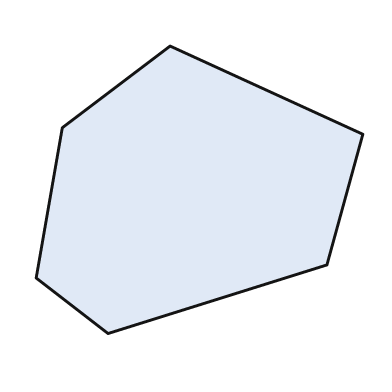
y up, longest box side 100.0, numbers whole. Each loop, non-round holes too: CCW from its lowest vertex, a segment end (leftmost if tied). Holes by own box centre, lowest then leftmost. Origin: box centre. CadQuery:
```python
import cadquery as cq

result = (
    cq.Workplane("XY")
    .moveTo(-28.0, -44.0)
    .lineTo(39.0, -23.0)
    .lineTo(50.0, 17.0)
    .lineTo(-9.0, 44.0)
    .lineTo(-42.0, 19.0)
    .lineTo(-50.0, -27.0)
    .close()
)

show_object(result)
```